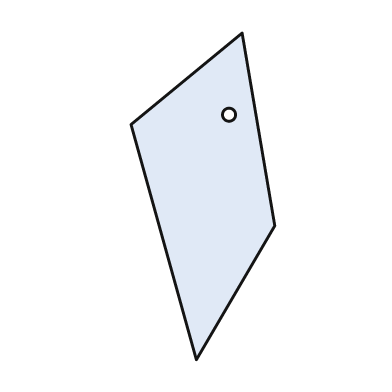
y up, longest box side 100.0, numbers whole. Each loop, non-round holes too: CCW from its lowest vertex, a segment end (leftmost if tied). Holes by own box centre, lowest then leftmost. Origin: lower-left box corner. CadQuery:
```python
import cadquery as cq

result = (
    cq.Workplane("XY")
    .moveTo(20.0, 0.0)
    .lineTo(44.0, 41.0)
    .lineTo(34.0, 100.0)
    .lineTo(0.0, 72.0)
    .close()
    .moveTo(30.0, 75.0)
    .circle(2.0)
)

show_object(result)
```